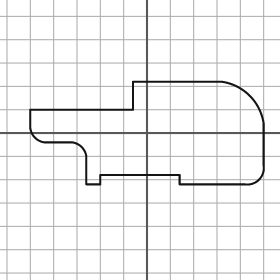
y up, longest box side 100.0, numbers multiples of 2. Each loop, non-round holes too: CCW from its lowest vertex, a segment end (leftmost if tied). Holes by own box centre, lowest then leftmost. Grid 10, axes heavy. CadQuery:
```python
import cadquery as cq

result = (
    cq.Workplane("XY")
    .moveTo(-26.0, -22.0)
    .lineTo(-20.0, -22.0)
    .lineTo(-20.0, -18.0)
    .lineTo(14.0, -18.0)
    .lineTo(14.0, -22.0)
    .lineTo(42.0, -22.0)
    .threePointArc((48.0, -20.0), (50.0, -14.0))
    .lineTo(50.0, 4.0)
    .threePointArc((44.0, 16.0), (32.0, 22.0))
    .lineTo(-6.0, 22.0)
    .lineTo(-6.0, 10.0)
    .lineTo(-50.0, 10.0)
    .lineTo(-50.0, 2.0)
    .threePointArc((-48.0, -2.0), (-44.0, -4.0))
    .lineTo(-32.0, -4.0)
    .threePointArc((-28.0, -6.0), (-26.0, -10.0))
    .close()
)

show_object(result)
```